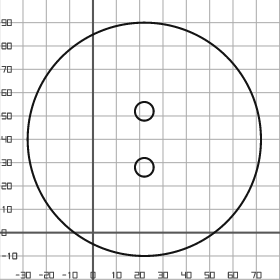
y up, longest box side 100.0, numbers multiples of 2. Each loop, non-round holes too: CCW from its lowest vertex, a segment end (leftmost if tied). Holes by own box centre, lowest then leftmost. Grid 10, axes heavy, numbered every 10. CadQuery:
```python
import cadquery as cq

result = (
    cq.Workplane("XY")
    .moveTo(22.0, 40.0)
    .circle(50.0)
    .moveTo(22.0, 28.0)
    .circle(4.0)
    .moveTo(22.0, 52.0)
    .circle(4.0)
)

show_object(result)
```